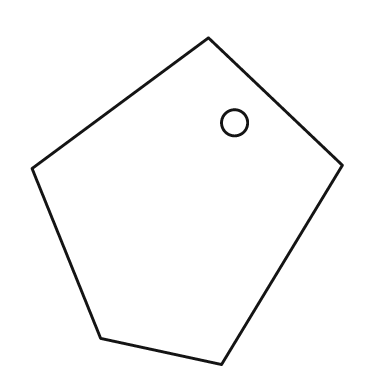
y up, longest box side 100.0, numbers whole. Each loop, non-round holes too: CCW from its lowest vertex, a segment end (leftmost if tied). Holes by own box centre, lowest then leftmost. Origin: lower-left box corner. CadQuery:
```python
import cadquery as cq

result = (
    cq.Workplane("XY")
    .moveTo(58.0, 0.0)
    .lineTo(95.0, 61.0)
    .lineTo(54.0, 100.0)
    .lineTo(0.0, 60.0)
    .lineTo(21.0, 8.0)
    .close()
    .moveTo(62.0, 74.0)
    .circle(4.0)
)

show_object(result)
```